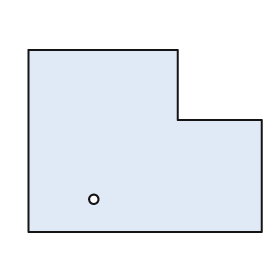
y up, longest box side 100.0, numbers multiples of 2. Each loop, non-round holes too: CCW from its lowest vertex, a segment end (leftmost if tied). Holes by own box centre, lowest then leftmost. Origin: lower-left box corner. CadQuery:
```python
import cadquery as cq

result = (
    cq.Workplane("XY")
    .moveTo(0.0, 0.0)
    .lineTo(100.0, 0.0)
    .lineTo(100.0, 48.0)
    .lineTo(64.0, 48.0)
    .lineTo(64.0, 78.0)
    .lineTo(0.0, 78.0)
    .close()
    .moveTo(28.0, 14.0)
    .circle(2.0)
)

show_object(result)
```